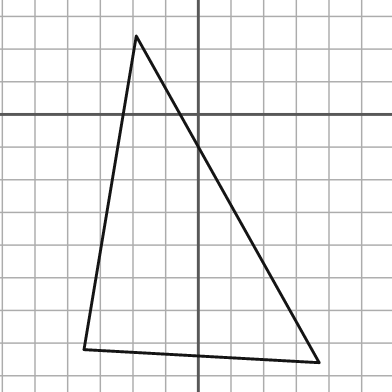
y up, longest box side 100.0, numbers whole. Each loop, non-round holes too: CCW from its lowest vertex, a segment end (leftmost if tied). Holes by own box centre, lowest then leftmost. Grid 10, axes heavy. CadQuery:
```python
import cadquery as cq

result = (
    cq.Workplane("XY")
    .moveTo(37.0, -76.0)
    .lineTo(-19.0, 24.0)
    .lineTo(-35.0, -72.0)
    .close()
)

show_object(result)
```